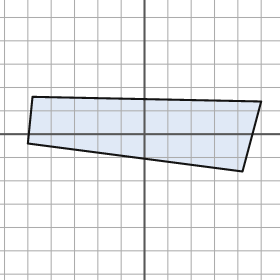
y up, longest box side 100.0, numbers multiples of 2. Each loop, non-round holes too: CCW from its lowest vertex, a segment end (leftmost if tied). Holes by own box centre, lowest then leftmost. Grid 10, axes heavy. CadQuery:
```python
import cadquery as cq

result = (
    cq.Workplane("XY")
    .moveTo(42.0, -16.0)
    .lineTo(50.0, 14.0)
    .lineTo(-48.0, 16.0)
    .lineTo(-50.0, -4.0)
    .close()
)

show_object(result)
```